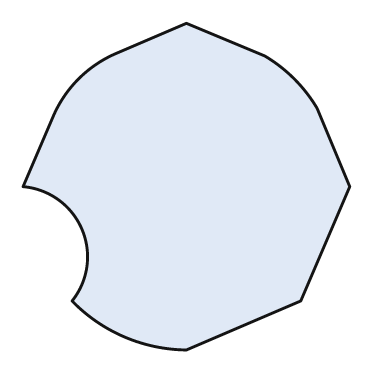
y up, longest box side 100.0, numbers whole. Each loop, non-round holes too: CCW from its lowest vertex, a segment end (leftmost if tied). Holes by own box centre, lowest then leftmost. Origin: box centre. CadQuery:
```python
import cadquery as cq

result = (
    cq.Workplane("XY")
    .moveTo(0.0, -50.0)
    .lineTo(35.0, -35.0)
    .lineTo(50.0, 0.0)
    .lineTo(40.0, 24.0)
    .threePointArc((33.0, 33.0), (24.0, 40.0))
    .lineTo(0.0, 50.0)
    .lineTo(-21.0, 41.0)
    .threePointArc((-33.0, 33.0), (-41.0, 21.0))
    .lineTo(-50.0, 0.0)
    .threePointArc((-32.0, -13.0), (-35.0, -35.0))
    .threePointArc((-19.0, -46.0), (0.0, -50.0))
    .close()
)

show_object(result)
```